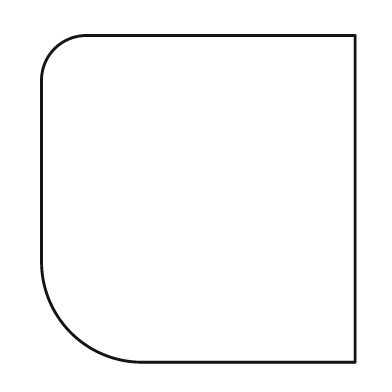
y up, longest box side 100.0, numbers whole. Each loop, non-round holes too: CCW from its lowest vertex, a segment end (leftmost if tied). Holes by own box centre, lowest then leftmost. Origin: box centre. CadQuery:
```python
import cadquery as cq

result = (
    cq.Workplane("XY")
    .moveTo(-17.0, -50.0)
    .lineTo(48.0, -50.0)
    .lineTo(48.0, 50.0)
    .lineTo(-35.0, 50.0)
    .threePointArc((-44.0, 46.0), (-48.0, 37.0))
    .lineTo(-48.0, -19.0)
    .threePointArc((-39.0, -41.0), (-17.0, -50.0))
    .close()
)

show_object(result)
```